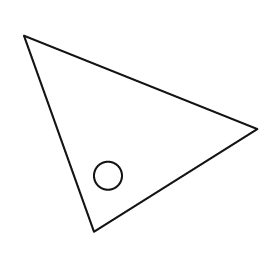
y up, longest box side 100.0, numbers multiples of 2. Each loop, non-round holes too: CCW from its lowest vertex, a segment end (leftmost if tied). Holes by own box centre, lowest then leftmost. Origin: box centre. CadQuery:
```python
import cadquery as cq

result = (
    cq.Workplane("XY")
    .moveTo(-20.0, -42.0)
    .lineTo(50.0, 2.0)
    .lineTo(-50.0, 42.0)
    .close()
    .moveTo(-14.0, -18.0)
    .circle(6.0)
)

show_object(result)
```